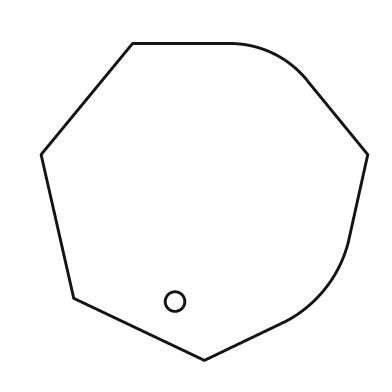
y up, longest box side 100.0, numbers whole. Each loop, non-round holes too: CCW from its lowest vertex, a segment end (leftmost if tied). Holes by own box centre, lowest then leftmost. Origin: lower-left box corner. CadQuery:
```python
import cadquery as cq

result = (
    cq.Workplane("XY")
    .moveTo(50.0, 0.0)
    .lineTo(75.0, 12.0)
    .threePointArc((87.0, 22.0), (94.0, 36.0))
    .lineTo(100.0, 63.0)
    .lineTo(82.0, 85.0)
    .threePointArc((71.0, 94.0), (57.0, 97.0))
    .lineTo(28.0, 97.0)
    .lineTo(0.0, 63.0)
    .lineTo(10.0, 19.0)
    .close()
    .moveTo(41.0, 18.0)
    .circle(3.0)
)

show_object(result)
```